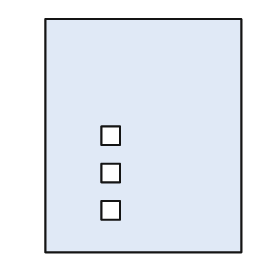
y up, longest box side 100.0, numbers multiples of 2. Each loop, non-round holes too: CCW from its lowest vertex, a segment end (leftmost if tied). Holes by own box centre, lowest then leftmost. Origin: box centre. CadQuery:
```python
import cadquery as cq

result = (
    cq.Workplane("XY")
    .moveTo(-42.0, -50.0)
    .lineTo(42.0, -50.0)
    .lineTo(42.0, 50.0)
    .lineTo(-42.0, 50.0)
    .close()
    .moveTo(-18.0, -36.0)
    .lineTo(-10.0, -36.0)
    .lineTo(-10.0, -28.0)
    .lineTo(-18.0, -28.0)
    .close()
    .moveTo(-18.0, -20.0)
    .lineTo(-10.0, -20.0)
    .lineTo(-10.0, -12.0)
    .lineTo(-18.0, -12.0)
    .close()
    .moveTo(-18.0, -4.0)
    .lineTo(-10.0, -4.0)
    .lineTo(-10.0, 4.0)
    .lineTo(-18.0, 4.0)
    .close()
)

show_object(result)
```